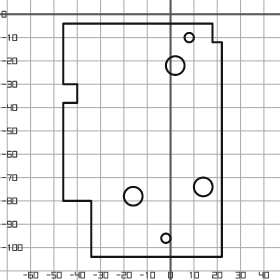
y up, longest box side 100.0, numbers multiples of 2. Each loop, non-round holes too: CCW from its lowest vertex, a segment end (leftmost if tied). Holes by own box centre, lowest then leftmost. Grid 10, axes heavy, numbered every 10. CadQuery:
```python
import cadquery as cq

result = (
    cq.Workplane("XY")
    .moveTo(-34.0, -104.0)
    .lineTo(22.0, -104.0)
    .lineTo(22.0, -12.0)
    .lineTo(18.0, -12.0)
    .lineTo(18.0, -4.0)
    .lineTo(-46.0, -4.0)
    .lineTo(-46.0, -30.0)
    .lineTo(-40.0, -30.0)
    .lineTo(-40.0, -38.0)
    .lineTo(-46.0, -38.0)
    .lineTo(-46.0, -80.0)
    .lineTo(-34.0, -80.0)
    .close()
    .moveTo(-2.0, -96.0)
    .circle(2.0)
    .moveTo(-16.0, -78.0)
    .circle(4.0)
    .moveTo(14.0, -74.0)
    .circle(4.0)
    .moveTo(2.0, -22.0)
    .circle(4.0)
    .moveTo(8.0, -10.0)
    .circle(2.0)
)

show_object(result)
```